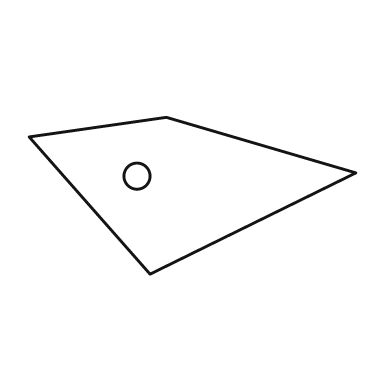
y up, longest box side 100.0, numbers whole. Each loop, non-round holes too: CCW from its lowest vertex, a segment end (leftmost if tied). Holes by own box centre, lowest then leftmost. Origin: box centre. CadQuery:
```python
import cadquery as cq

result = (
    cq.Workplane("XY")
    .moveTo(-13.0, -24.0)
    .lineTo(50.0, 7.0)
    .lineTo(-8.0, 24.0)
    .lineTo(-50.0, 18.0)
    .close()
    .moveTo(-17.0, 6.0)
    .circle(4.0)
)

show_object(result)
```